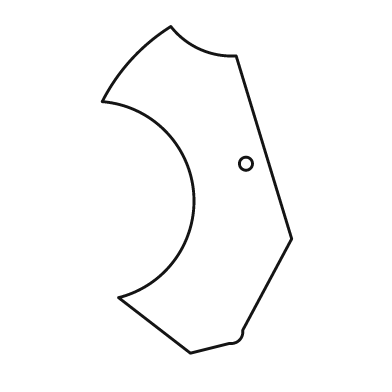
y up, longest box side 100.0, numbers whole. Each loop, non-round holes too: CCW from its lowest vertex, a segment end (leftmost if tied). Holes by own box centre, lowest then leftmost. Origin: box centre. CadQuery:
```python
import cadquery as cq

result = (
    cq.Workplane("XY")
    .moveTo(-2.0, -50.0)
    .lineTo(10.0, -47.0)
    .threePointArc((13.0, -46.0), (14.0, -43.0))
    .lineTo(29.0, -15.0)
    .lineTo(12.0, 41.0)
    .threePointArc((1.0, 43.0), (-8.0, 50.0))
    .threePointArc((-20.0, 40.0), (-29.0, 27.0))
    .threePointArc((-1.0, -1.0), (-24.0, -33.0))
    .close()
    .moveTo(15.0, 8.0)
    .circle(2.0)
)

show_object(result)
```